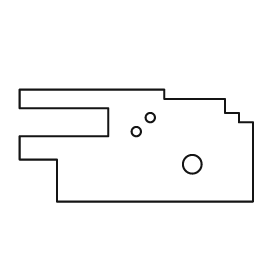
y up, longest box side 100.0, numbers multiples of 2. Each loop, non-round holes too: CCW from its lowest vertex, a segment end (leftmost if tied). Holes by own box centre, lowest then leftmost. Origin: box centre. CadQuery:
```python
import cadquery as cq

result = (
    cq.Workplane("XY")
    .moveTo(-34.0, -24.0)
    .lineTo(50.0, -24.0)
    .lineTo(50.0, 10.0)
    .lineTo(44.0, 10.0)
    .lineTo(44.0, 14.0)
    .lineTo(38.0, 14.0)
    .lineTo(38.0, 20.0)
    .lineTo(12.0, 20.0)
    .lineTo(12.0, 24.0)
    .lineTo(-50.0, 24.0)
    .lineTo(-50.0, 16.0)
    .lineTo(-12.0, 16.0)
    .lineTo(-12.0, 4.0)
    .lineTo(-50.0, 4.0)
    .lineTo(-50.0, -6.0)
    .lineTo(-34.0, -6.0)
    .close()
    .moveTo(24.0, -8.0)
    .circle(4.0)
    .moveTo(0.0, 6.0)
    .circle(2.0)
    .moveTo(6.0, 12.0)
    .circle(2.0)
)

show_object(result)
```